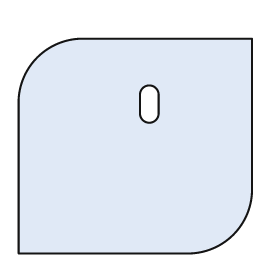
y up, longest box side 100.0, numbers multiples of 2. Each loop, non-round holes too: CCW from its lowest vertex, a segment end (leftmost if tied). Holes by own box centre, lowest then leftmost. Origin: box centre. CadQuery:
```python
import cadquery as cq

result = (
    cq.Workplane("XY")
    .moveTo(-50.0, -46.0)
    .lineTo(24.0, -46.0)
    .threePointArc((42.0, -38.0), (50.0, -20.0))
    .lineTo(50.0, 46.0)
    .lineTo(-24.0, 46.0)
    .threePointArc((-42.0, 38.0), (-50.0, 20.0))
    .close()
    .moveTo(2.0, 14.0)
    .threePointArc((6.0, 10.0), (10.0, 14.0))
    .lineTo(10.0, 22.0)
    .threePointArc((6.0, 26.0), (2.0, 22.0))
    .close()
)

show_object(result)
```